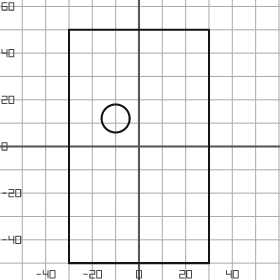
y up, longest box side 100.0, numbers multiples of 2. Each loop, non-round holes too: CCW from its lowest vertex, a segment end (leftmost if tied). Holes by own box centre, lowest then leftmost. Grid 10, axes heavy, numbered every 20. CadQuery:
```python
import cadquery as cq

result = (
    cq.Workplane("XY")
    .moveTo(-30.0, -50.0)
    .lineTo(30.0, -50.0)
    .lineTo(30.0, 50.0)
    .lineTo(-30.0, 50.0)
    .close()
    .moveTo(-10.0, 12.0)
    .circle(6.0)
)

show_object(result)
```